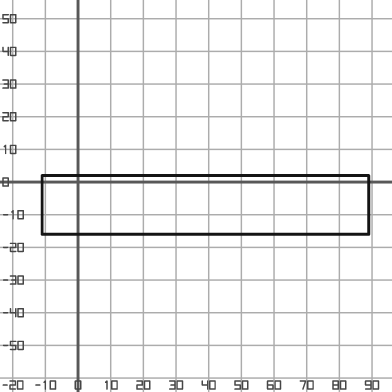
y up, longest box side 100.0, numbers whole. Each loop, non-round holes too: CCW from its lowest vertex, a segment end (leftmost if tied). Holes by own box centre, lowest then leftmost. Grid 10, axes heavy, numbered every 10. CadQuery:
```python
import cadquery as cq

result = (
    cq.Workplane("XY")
    .moveTo(-11.0, -16.0)
    .lineTo(89.0, -16.0)
    .lineTo(89.0, 2.0)
    .lineTo(-11.0, 2.0)
    .close()
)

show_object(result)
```